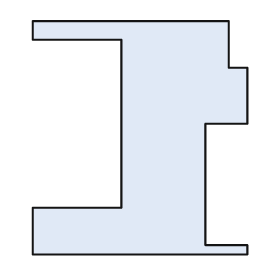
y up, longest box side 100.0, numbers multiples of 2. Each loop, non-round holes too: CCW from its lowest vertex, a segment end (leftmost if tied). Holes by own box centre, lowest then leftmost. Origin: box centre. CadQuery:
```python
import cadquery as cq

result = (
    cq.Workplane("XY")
    .moveTo(-46.0, -50.0)
    .lineTo(46.0, -50.0)
    .lineTo(46.0, -46.0)
    .lineTo(28.0, -46.0)
    .lineTo(28.0, 6.0)
    .lineTo(46.0, 6.0)
    .lineTo(46.0, 30.0)
    .lineTo(38.0, 30.0)
    .lineTo(38.0, 50.0)
    .lineTo(-46.0, 50.0)
    .lineTo(-46.0, 42.0)
    .lineTo(-8.0, 42.0)
    .lineTo(-8.0, -30.0)
    .lineTo(-46.0, -30.0)
    .close()
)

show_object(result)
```